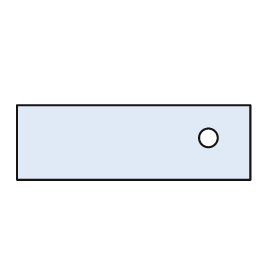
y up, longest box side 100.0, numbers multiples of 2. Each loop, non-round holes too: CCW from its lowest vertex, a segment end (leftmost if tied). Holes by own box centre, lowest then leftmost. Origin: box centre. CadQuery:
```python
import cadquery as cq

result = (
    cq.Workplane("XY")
    .moveTo(-50.0, -16.0)
    .lineTo(50.0, -16.0)
    .lineTo(50.0, 16.0)
    .lineTo(-50.0, 16.0)
    .close()
    .moveTo(32.0, 2.0)
    .circle(4.0)
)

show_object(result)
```